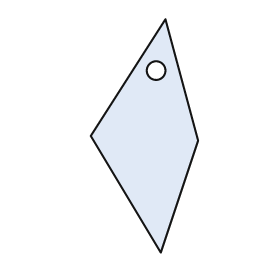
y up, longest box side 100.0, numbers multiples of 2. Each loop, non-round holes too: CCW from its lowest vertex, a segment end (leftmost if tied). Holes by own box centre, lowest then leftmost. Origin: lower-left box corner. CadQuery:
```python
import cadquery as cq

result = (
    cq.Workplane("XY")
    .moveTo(30.0, 0.0)
    .lineTo(46.0, 48.0)
    .lineTo(32.0, 100.0)
    .lineTo(0.0, 50.0)
    .close()
    .moveTo(28.0, 78.0)
    .circle(4.0)
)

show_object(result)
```